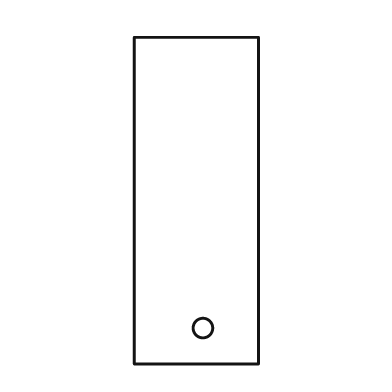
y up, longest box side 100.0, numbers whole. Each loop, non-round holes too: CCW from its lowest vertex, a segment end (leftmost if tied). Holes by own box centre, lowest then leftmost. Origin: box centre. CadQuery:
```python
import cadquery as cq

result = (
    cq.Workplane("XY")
    .moveTo(-19.0, -50.0)
    .lineTo(19.0, -50.0)
    .lineTo(19.0, 50.0)
    .lineTo(-19.0, 50.0)
    .close()
    .moveTo(2.0, -39.0)
    .circle(3.0)
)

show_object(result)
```